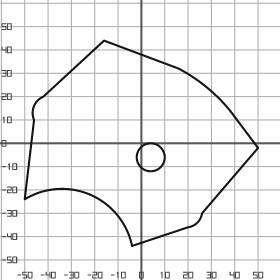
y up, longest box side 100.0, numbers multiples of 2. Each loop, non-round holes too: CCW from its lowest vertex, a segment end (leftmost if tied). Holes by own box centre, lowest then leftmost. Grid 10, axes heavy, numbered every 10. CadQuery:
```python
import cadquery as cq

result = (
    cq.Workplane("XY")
    .moveTo(-4.0, -44.0)
    .lineTo(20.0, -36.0)
    .threePointArc((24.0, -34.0), (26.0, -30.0))
    .lineTo(50.0, -2.0)
    .lineTo(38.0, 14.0)
    .threePointArc((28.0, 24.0), (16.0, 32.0))
    .lineTo(-16.0, 44.0)
    .lineTo(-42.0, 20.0)
    .threePointArc((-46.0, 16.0), (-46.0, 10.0))
    .lineTo(-50.0, -24.0)
    .threePointArc((-22.0, -22.0), (-4.0, -44.0))
    .close()
    .moveTo(4.0, -6.0)
    .circle(6.0)
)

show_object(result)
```